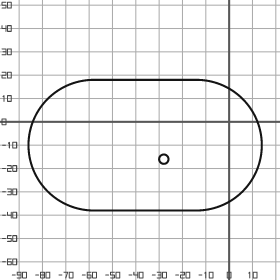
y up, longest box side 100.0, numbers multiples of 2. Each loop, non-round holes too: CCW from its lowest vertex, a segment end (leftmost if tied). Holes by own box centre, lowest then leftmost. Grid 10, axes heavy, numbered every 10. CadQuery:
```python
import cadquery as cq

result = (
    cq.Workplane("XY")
    .moveTo(-58.0, -38.0)
    .lineTo(-14.0, -38.0)
    .threePointArc((14.0, -10.0), (-14.0, 18.0))
    .lineTo(-58.0, 18.0)
    .threePointArc((-86.0, -10.0), (-58.0, -38.0))
    .close()
    .moveTo(-28.0, -16.0)
    .circle(2.0)
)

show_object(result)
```